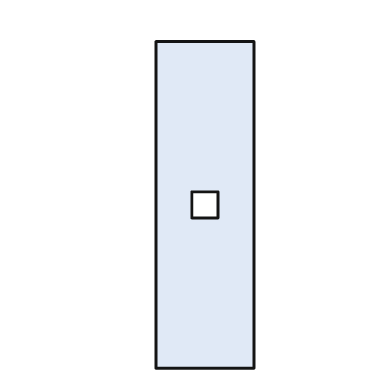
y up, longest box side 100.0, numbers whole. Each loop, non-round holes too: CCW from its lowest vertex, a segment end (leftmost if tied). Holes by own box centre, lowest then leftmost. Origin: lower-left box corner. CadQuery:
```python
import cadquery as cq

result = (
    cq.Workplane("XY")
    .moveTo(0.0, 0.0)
    .lineTo(30.0, 0.0)
    .lineTo(30.0, 100.0)
    .lineTo(0.0, 100.0)
    .close()
    .moveTo(11.0, 46.0)
    .lineTo(19.0, 46.0)
    .lineTo(19.0, 54.0)
    .lineTo(11.0, 54.0)
    .close()
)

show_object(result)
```